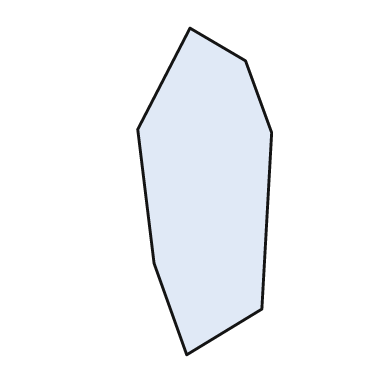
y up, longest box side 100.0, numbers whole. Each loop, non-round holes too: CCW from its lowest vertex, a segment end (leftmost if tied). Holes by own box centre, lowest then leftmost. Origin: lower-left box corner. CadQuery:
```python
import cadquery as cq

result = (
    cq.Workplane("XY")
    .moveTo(15.0, 0.0)
    .lineTo(38.0, 14.0)
    .lineTo(41.0, 68.0)
    .lineTo(33.0, 90.0)
    .lineTo(16.0, 100.0)
    .lineTo(0.0, 69.0)
    .lineTo(5.0, 28.0)
    .close()
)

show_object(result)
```